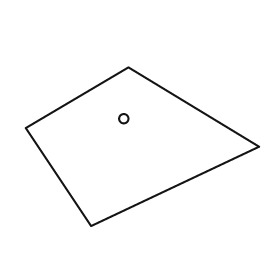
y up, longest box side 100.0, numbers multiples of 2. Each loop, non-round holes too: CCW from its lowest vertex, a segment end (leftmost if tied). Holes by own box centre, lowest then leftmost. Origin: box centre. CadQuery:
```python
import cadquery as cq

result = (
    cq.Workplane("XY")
    .moveTo(-22.0, -34.0)
    .lineTo(50.0, 0.0)
    .lineTo(-6.0, 34.0)
    .lineTo(-50.0, 8.0)
    .close()
    .moveTo(-8.0, 12.0)
    .circle(2.0)
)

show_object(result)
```